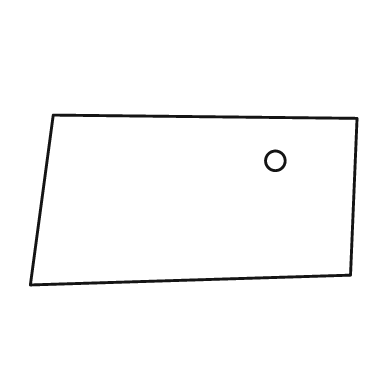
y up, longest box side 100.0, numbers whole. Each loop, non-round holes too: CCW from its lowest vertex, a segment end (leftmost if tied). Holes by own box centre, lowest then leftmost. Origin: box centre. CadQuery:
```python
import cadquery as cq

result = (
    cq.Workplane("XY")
    .moveTo(-50.0, -26.0)
    .lineTo(48.0, -23.0)
    .lineTo(50.0, 25.0)
    .lineTo(-43.0, 26.0)
    .close()
    .moveTo(25.0, 12.0)
    .circle(3.0)
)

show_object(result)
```